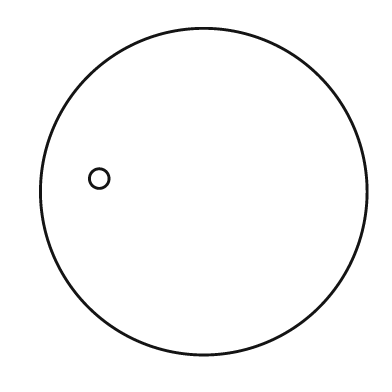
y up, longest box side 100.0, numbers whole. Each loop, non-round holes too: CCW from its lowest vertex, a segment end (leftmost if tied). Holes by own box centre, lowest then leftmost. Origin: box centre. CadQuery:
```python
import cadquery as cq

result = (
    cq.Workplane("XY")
    .moveTo(0.0, 0.0)
    .circle(50.0)
    .moveTo(-32.0, 4.0)
    .circle(3.0)
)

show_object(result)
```